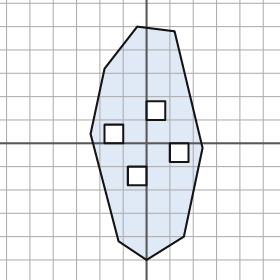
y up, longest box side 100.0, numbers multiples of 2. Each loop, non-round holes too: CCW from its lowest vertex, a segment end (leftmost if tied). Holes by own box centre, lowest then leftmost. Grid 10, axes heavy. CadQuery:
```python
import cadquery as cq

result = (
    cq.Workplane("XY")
    .moveTo(0.0, -50.0)
    .lineTo(16.0, -40.0)
    .lineTo(24.0, -2.0)
    .lineTo(12.0, 48.0)
    .lineTo(-4.0, 50.0)
    .lineTo(-18.0, 32.0)
    .lineTo(-24.0, 4.0)
    .lineTo(-12.0, -42.0)
    .close()
    .moveTo(-8.0, -18.0)
    .lineTo(0.0, -18.0)
    .lineTo(0.0, -10.0)
    .lineTo(-8.0, -10.0)
    .close()
    .moveTo(10.0, -8.0)
    .lineTo(18.0, -8.0)
    .lineTo(18.0, 0.0)
    .lineTo(10.0, 0.0)
    .close()
    .moveTo(-18.0, 0.0)
    .lineTo(-10.0, 0.0)
    .lineTo(-10.0, 8.0)
    .lineTo(-18.0, 8.0)
    .close()
    .moveTo(0.0, 10.0)
    .lineTo(8.0, 10.0)
    .lineTo(8.0, 18.0)
    .lineTo(0.0, 18.0)
    .close()
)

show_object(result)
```